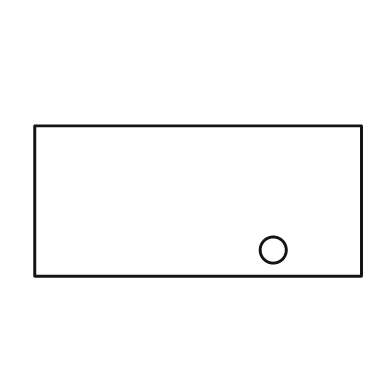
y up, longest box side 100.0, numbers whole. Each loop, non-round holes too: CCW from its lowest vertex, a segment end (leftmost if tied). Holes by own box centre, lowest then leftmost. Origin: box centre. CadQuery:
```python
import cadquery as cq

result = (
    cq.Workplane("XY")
    .moveTo(-50.0, -23.0)
    .lineTo(50.0, -23.0)
    .lineTo(50.0, 23.0)
    .lineTo(-50.0, 23.0)
    .close()
    .moveTo(23.0, -15.0)
    .circle(4.0)
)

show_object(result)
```